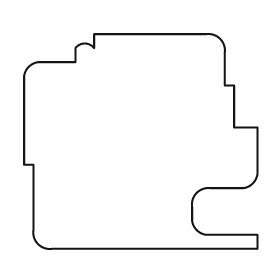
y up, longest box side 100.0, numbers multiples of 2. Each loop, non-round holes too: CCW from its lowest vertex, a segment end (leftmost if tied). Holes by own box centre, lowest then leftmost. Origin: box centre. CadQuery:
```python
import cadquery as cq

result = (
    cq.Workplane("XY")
    .moveTo(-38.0, -46.0)
    .lineTo(50.0, -46.0)
    .lineTo(50.0, -40.0)
    .lineTo(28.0, -40.0)
    .threePointArc((24.0, -38.0), (22.0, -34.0))
    .lineTo(22.0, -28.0)
    .threePointArc((24.0, -22.0), (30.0, -20.0))
    .lineTo(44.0, -20.0)
    .threePointArc((48.0, -18.0), (50.0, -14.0))
    .lineTo(50.0, 6.0)
    .lineTo(40.0, 6.0)
    .lineTo(40.0, 24.0)
    .lineTo(36.0, 24.0)
    .lineTo(36.0, 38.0)
    .threePointArc((34.0, 44.0), (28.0, 46.0))
    .lineTo(-20.0, 46.0)
    .lineTo(-20.0, 40.0)
    .threePointArc((-24.0, 42.0), (-28.0, 40.0))
    .lineTo(-28.0, 34.0)
    .lineTo(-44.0, 34.0)
    .threePointArc((-48.0, 32.0), (-50.0, 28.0))
    .lineTo(-50.0, -10.0)
    .lineTo(-46.0, -10.0)
    .lineTo(-46.0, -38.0)
    .threePointArc((-44.0, -44.0), (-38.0, -46.0))
    .close()
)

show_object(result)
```